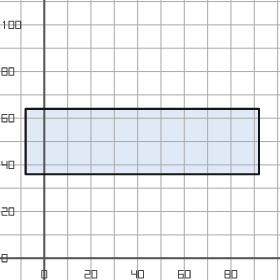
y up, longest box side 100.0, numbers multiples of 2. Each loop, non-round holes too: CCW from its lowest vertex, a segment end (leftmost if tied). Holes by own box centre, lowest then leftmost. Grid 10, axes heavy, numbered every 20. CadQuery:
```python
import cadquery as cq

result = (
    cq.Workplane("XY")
    .moveTo(-8.0, 36.0)
    .lineTo(92.0, 36.0)
    .lineTo(92.0, 64.0)
    .lineTo(-8.0, 64.0)
    .close()
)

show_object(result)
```